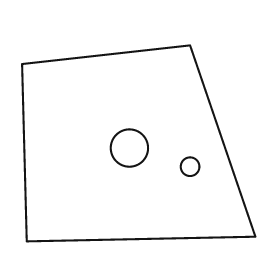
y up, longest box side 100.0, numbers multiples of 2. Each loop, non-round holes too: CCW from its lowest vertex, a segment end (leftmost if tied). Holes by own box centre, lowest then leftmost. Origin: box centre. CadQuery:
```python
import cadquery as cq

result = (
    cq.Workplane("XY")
    .moveTo(-48.0, -42.0)
    .lineTo(50.0, -40.0)
    .lineTo(22.0, 42.0)
    .lineTo(-50.0, 34.0)
    .close()
    .moveTo(22.0, -10.0)
    .circle(4.0)
    .moveTo(-4.0, -2.0)
    .circle(8.0)
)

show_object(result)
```